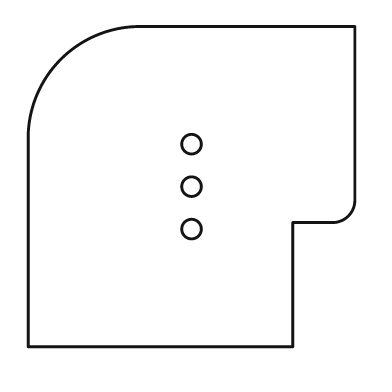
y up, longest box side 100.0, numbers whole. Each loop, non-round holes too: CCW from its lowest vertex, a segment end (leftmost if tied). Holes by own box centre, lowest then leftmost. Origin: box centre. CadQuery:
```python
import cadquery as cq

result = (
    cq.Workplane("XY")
    .moveTo(-50.0, -49.0)
    .lineTo(31.0, -49.0)
    .lineTo(31.0, -11.0)
    .lineTo(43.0, -11.0)
    .threePointArc((48.0, -9.0), (50.0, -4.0))
    .lineTo(50.0, 49.0)
    .lineTo(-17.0, 49.0)
    .threePointArc((-40.0, 39.0), (-50.0, 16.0))
    .close()
    .moveTo(0.0, -13.0)
    .circle(3.0)
    .moveTo(0.0, 0.0)
    .circle(3.0)
    .moveTo(0.0, 13.0)
    .circle(3.0)
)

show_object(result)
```